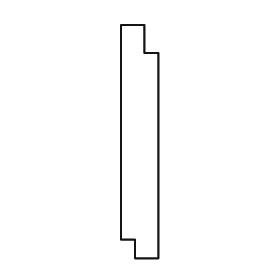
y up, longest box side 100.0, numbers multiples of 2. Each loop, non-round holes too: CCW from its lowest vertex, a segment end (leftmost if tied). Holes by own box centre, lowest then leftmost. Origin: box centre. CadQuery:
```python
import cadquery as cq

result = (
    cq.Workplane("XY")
    .moveTo(-2.0, -50.0)
    .lineTo(8.0, -50.0)
    .lineTo(8.0, 38.0)
    .lineTo(2.0, 38.0)
    .lineTo(2.0, 50.0)
    .lineTo(-8.0, 50.0)
    .lineTo(-8.0, -42.0)
    .lineTo(-2.0, -42.0)
    .close()
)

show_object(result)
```